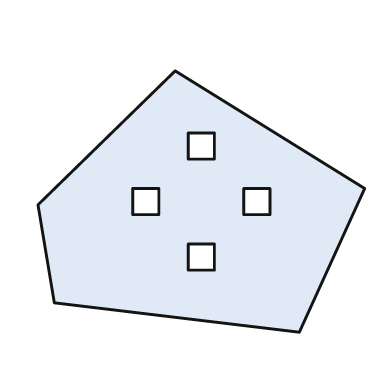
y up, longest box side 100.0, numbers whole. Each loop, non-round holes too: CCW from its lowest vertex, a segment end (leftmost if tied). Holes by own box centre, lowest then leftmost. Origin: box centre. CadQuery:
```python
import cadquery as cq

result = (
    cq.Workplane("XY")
    .moveTo(30.0, -40.0)
    .lineTo(50.0, 4.0)
    .lineTo(-8.0, 40.0)
    .lineTo(-50.0, -1.0)
    .lineTo(-45.0, -31.0)
    .close()
    .moveTo(-4.0, -21.0)
    .lineTo(4.0, -21.0)
    .lineTo(4.0, -13.0)
    .lineTo(-4.0, -13.0)
    .close()
    .moveTo(-21.0, -4.0)
    .lineTo(-13.0, -4.0)
    .lineTo(-13.0, 4.0)
    .lineTo(-21.0, 4.0)
    .close()
    .moveTo(13.0, -4.0)
    .lineTo(21.0, -4.0)
    .lineTo(21.0, 4.0)
    .lineTo(13.0, 4.0)
    .close()
    .moveTo(-4.0, 13.0)
    .lineTo(4.0, 13.0)
    .lineTo(4.0, 21.0)
    .lineTo(-4.0, 21.0)
    .close()
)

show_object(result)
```